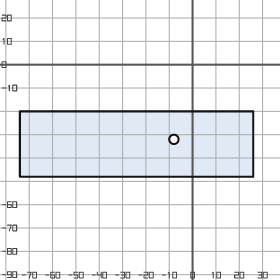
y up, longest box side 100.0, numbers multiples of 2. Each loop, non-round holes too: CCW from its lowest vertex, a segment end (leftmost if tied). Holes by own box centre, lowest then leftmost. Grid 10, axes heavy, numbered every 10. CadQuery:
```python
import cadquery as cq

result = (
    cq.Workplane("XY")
    .moveTo(-74.0, -48.0)
    .lineTo(26.0, -48.0)
    .lineTo(26.0, -20.0)
    .lineTo(-74.0, -20.0)
    .close()
    .moveTo(-8.0, -32.0)
    .circle(2.0)
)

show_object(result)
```